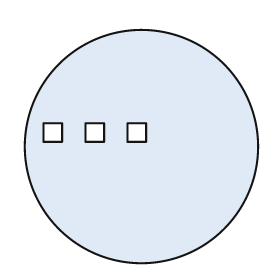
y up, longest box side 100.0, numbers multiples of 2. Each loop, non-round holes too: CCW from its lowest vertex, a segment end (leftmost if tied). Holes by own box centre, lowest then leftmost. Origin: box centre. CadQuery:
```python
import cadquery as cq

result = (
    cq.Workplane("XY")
    .moveTo(0.0, 0.0)
    .circle(50.0)
    .moveTo(-42.0, 2.0)
    .lineTo(-34.0, 2.0)
    .lineTo(-34.0, 10.0)
    .lineTo(-42.0, 10.0)
    .close()
    .moveTo(-24.0, 2.0)
    .lineTo(-16.0, 2.0)
    .lineTo(-16.0, 10.0)
    .lineTo(-24.0, 10.0)
    .close()
    .moveTo(-6.0, 2.0)
    .lineTo(2.0, 2.0)
    .lineTo(2.0, 10.0)
    .lineTo(-6.0, 10.0)
    .close()
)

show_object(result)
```